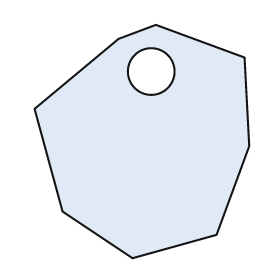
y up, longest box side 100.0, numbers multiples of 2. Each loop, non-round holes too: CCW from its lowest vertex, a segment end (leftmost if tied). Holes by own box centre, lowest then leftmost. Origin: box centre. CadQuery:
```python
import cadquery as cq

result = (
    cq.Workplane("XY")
    .moveTo(-4.0, -50.0)
    .lineTo(32.0, -40.0)
    .lineTo(46.0, -2.0)
    .lineTo(44.0, 36.0)
    .lineTo(6.0, 50.0)
    .lineTo(-10.0, 44.0)
    .lineTo(-46.0, 14.0)
    .lineTo(-34.0, -30.0)
    .close()
    .moveTo(4.0, 30.0)
    .circle(10.0)
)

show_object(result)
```